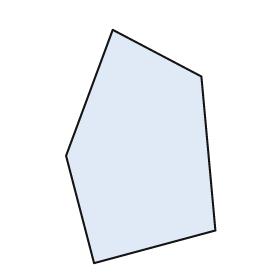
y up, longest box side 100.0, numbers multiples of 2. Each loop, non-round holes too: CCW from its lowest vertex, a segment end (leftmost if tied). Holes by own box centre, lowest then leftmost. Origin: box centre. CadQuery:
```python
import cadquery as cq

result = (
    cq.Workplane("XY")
    .moveTo(-20.0, -50.0)
    .lineTo(32.0, -36.0)
    .lineTo(26.0, 30.0)
    .lineTo(-12.0, 50.0)
    .lineTo(-32.0, -4.0)
    .close()
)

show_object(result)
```